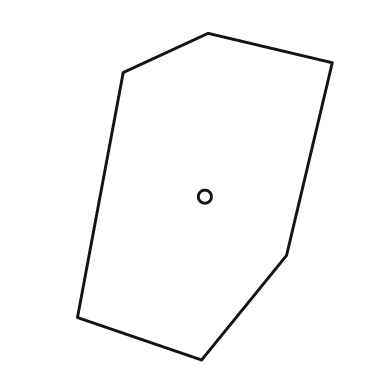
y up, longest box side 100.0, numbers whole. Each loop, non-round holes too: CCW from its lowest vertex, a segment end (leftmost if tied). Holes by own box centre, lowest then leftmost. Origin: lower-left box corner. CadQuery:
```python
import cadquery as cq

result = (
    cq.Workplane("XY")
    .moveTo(38.0, 0.0)
    .lineTo(64.0, 32.0)
    .lineTo(78.0, 91.0)
    .lineTo(40.0, 100.0)
    .lineTo(14.0, 88.0)
    .lineTo(0.0, 13.0)
    .close()
    .moveTo(39.0, 50.0)
    .circle(2.0)
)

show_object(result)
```